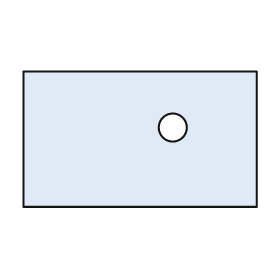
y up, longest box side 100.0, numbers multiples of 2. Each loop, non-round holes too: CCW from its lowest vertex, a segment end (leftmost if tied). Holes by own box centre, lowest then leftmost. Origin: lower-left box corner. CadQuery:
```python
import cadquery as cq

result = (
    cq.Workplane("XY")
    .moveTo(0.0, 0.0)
    .lineTo(100.0, 0.0)
    .lineTo(100.0, 58.0)
    .lineTo(0.0, 58.0)
    .close()
    .moveTo(64.0, 34.0)
    .circle(6.0)
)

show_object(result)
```